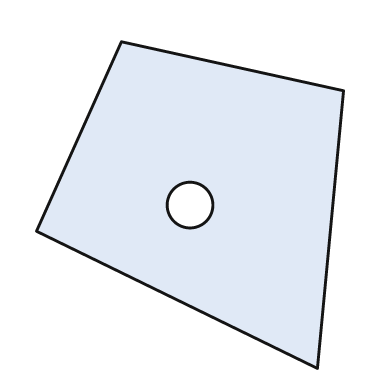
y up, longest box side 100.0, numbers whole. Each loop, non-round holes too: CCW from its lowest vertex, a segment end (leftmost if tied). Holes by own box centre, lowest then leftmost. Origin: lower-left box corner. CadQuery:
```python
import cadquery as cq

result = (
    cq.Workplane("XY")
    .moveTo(86.0, 0.0)
    .lineTo(94.0, 85.0)
    .lineTo(26.0, 100.0)
    .lineTo(0.0, 42.0)
    .close()
    .moveTo(47.0, 50.0)
    .circle(7.0)
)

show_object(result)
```